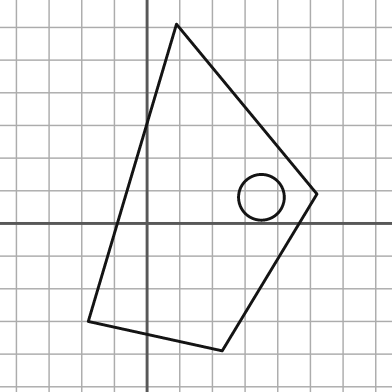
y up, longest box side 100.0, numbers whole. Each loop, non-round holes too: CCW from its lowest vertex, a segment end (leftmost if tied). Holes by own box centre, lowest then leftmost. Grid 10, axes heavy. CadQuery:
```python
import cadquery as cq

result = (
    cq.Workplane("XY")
    .moveTo(23.0, -39.0)
    .lineTo(52.0, 9.0)
    .lineTo(9.0, 61.0)
    .lineTo(-18.0, -30.0)
    .close()
    .moveTo(35.0, 8.0)
    .circle(7.0)
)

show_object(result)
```